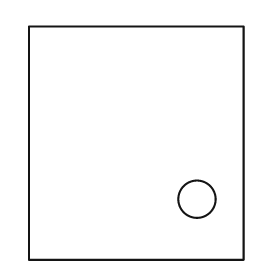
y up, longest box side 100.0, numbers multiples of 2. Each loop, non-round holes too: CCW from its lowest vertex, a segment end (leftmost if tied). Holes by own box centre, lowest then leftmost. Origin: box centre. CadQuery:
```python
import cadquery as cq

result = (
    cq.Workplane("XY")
    .moveTo(-46.0, -50.0)
    .lineTo(46.0, -50.0)
    .lineTo(46.0, 50.0)
    .lineTo(-46.0, 50.0)
    .close()
    .moveTo(26.0, -24.0)
    .circle(8.0)
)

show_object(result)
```